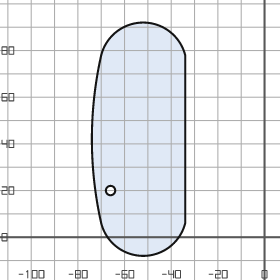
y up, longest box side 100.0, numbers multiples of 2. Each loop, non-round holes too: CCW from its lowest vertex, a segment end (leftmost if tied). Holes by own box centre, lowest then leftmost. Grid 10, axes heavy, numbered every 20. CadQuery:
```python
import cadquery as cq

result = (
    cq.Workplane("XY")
    .moveTo(-70.0, 6.0)
    .threePointArc((-52.0, -8.0), (-34.0, 6.0))
    .lineTo(-34.0, 78.0)
    .threePointArc((-52.0, 92.0), (-70.0, 78.0))
    .threePointArc((-74.0, 42.0), (-70.0, 6.0))
    .close()
    .moveTo(-66.0, 20.0)
    .circle(2.0)
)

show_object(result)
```